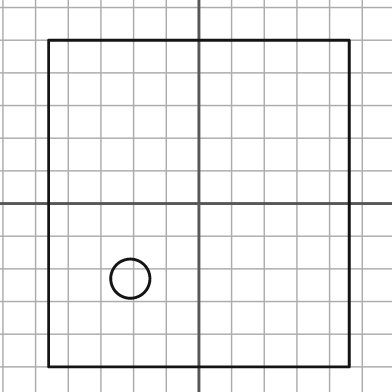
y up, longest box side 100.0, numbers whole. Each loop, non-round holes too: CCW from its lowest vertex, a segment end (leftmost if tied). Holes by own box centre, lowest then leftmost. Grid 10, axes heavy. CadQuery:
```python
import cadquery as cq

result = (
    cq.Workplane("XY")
    .moveTo(-46.0, -50.0)
    .lineTo(46.0, -50.0)
    .lineTo(46.0, 50.0)
    .lineTo(-46.0, 50.0)
    .close()
    .moveTo(-21.0, -23.0)
    .circle(6.0)
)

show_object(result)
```